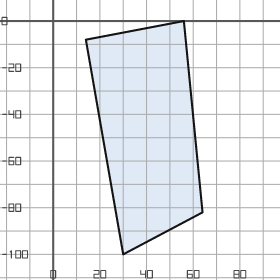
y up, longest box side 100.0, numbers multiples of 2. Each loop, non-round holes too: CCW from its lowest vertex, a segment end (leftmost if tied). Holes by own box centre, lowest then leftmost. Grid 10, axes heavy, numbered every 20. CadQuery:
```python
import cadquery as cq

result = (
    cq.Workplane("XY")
    .moveTo(30.0, -100.0)
    .lineTo(64.0, -82.0)
    .lineTo(56.0, 0.0)
    .lineTo(14.0, -8.0)
    .close()
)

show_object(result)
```